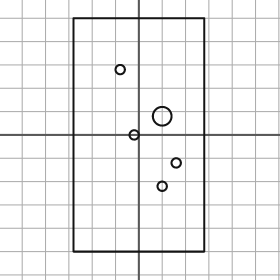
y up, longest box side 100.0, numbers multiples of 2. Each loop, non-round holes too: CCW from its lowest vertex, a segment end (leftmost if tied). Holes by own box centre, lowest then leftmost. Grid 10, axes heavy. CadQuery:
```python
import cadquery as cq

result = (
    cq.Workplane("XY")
    .moveTo(-28.0, -50.0)
    .lineTo(28.0, -50.0)
    .lineTo(28.0, 50.0)
    .lineTo(-28.0, 50.0)
    .close()
    .moveTo(10.0, -22.0)
    .circle(2.0)
    .moveTo(16.0, -12.0)
    .circle(2.0)
    .moveTo(-2.0, 0.0)
    .circle(2.0)
    .moveTo(10.0, 8.0)
    .circle(4.0)
    .moveTo(-8.0, 28.0)
    .circle(2.0)
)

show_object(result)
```